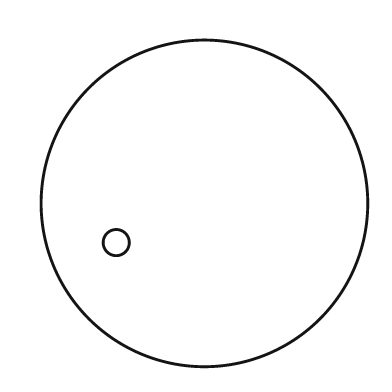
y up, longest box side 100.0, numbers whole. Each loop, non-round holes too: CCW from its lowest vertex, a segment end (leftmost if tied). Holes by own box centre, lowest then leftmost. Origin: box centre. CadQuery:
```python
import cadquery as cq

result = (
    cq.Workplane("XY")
    .moveTo(0.0, 0.0)
    .circle(50.0)
    .moveTo(-27.0, -12.0)
    .circle(4.0)
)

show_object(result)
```